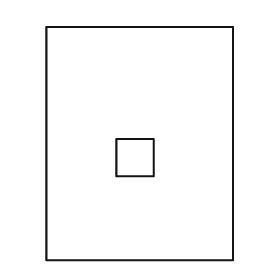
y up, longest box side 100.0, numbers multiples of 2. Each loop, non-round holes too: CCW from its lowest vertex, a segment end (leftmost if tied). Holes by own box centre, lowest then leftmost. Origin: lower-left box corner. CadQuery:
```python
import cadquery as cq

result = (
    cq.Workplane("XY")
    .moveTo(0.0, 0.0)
    .lineTo(80.0, 0.0)
    .lineTo(80.0, 100.0)
    .lineTo(0.0, 100.0)
    .close()
    .moveTo(30.0, 36.0)
    .lineTo(46.0, 36.0)
    .lineTo(46.0, 52.0)
    .lineTo(30.0, 52.0)
    .close()
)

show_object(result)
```